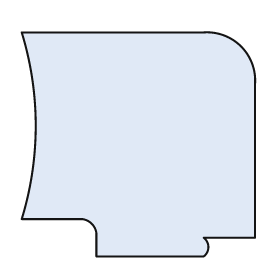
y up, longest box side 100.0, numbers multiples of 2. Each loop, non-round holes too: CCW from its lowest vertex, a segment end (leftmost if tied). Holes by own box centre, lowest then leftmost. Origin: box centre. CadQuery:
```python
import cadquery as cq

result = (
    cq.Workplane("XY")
    .moveTo(-18.0, -48.0)
    .lineTo(28.0, -48.0)
    .threePointArc((30.0, -44.0), (28.0, -40.0))
    .lineTo(50.0, -40.0)
    .lineTo(50.0, 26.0)
    .threePointArc((44.0, 42.0), (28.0, 48.0))
    .lineTo(-50.0, 48.0)
    .threePointArc((-44.0, 8.0), (-50.0, -32.0))
    .lineTo(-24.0, -32.0)
    .threePointArc((-20.0, -34.0), (-18.0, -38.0))
    .close()
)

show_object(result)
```